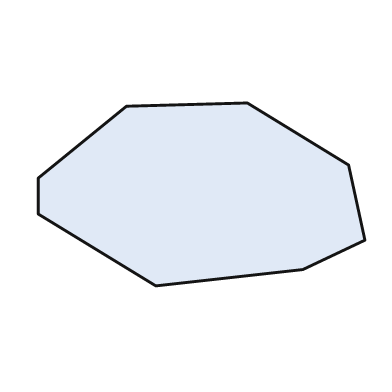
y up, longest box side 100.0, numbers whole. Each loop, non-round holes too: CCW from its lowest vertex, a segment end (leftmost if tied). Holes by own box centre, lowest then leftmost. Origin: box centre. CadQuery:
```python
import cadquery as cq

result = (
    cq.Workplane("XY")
    .moveTo(-14.0, -28.0)
    .lineTo(31.0, -23.0)
    .lineTo(50.0, -14.0)
    .lineTo(45.0, 9.0)
    .lineTo(14.0, 28.0)
    .lineTo(-23.0, 27.0)
    .lineTo(-50.0, 5.0)
    .lineTo(-50.0, -6.0)
    .close()
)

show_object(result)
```